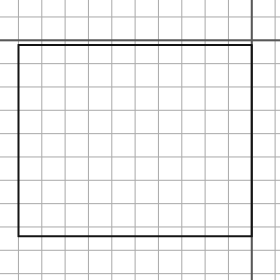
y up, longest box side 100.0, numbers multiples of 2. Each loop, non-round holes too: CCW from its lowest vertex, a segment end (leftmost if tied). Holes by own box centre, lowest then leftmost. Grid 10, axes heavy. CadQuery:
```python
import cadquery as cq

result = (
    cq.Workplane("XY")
    .moveTo(-100.0, -84.0)
    .lineTo(0.0, -84.0)
    .lineTo(0.0, -2.0)
    .lineTo(-100.0, -2.0)
    .close()
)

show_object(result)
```